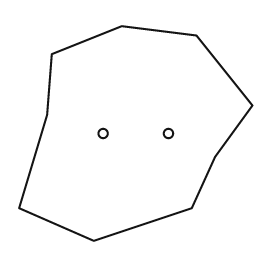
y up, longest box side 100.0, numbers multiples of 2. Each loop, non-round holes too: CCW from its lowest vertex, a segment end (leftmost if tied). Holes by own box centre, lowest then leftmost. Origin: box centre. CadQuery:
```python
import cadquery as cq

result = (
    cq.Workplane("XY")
    .moveTo(-18.0, -46.0)
    .lineTo(24.0, -32.0)
    .lineTo(34.0, -10.0)
    .lineTo(50.0, 12.0)
    .lineTo(26.0, 42.0)
    .lineTo(-6.0, 46.0)
    .lineTo(-36.0, 34.0)
    .lineTo(-38.0, 8.0)
    .lineTo(-50.0, -32.0)
    .close()
    .moveTo(-14.0, 0.0)
    .circle(2.0)
    .moveTo(14.0, 0.0)
    .circle(2.0)
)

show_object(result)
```